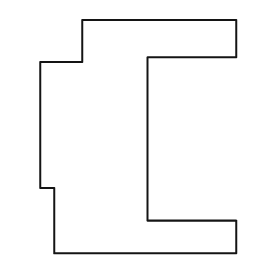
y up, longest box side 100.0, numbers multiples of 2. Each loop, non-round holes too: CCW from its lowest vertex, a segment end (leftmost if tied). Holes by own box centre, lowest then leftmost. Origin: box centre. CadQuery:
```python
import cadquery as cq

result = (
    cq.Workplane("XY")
    .moveTo(-36.0, -50.0)
    .lineTo(42.0, -50.0)
    .lineTo(42.0, -36.0)
    .lineTo(4.0, -36.0)
    .lineTo(4.0, 34.0)
    .lineTo(42.0, 34.0)
    .lineTo(42.0, 50.0)
    .lineTo(-24.0, 50.0)
    .lineTo(-24.0, 32.0)
    .lineTo(-42.0, 32.0)
    .lineTo(-42.0, -22.0)
    .lineTo(-36.0, -22.0)
    .close()
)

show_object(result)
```